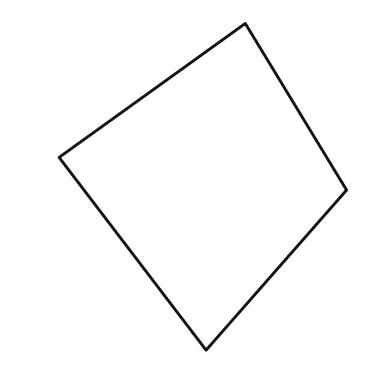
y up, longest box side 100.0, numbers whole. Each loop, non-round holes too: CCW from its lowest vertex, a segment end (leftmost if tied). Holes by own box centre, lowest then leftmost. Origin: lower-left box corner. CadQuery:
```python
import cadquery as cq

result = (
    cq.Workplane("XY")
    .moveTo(45.0, 0.0)
    .lineTo(88.0, 49.0)
    .lineTo(57.0, 100.0)
    .lineTo(0.0, 59.0)
    .close()
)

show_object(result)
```